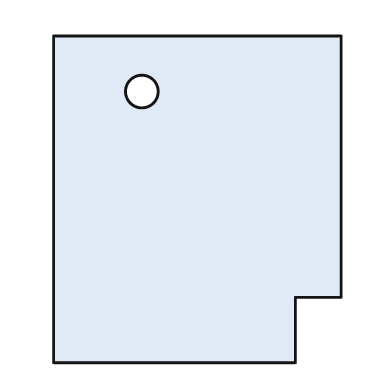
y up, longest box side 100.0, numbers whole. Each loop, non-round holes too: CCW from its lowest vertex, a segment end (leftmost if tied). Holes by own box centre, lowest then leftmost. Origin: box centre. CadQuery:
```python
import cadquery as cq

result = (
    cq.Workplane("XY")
    .moveTo(-44.0, -50.0)
    .lineTo(30.0, -50.0)
    .lineTo(30.0, -30.0)
    .lineTo(44.0, -30.0)
    .lineTo(44.0, 50.0)
    .lineTo(-44.0, 50.0)
    .close()
    .moveTo(-17.0, 33.0)
    .circle(5.0)
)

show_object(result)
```